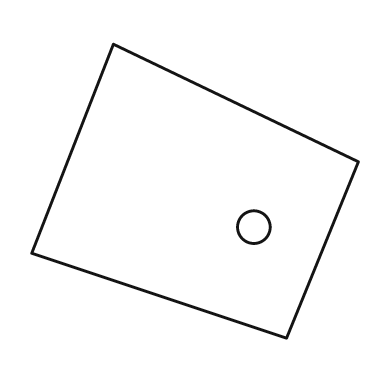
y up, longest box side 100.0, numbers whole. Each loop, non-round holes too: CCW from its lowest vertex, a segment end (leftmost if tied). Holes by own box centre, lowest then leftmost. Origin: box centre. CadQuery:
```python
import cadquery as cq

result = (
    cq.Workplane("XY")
    .moveTo(28.0, -45.0)
    .lineTo(50.0, 9.0)
    .lineTo(-25.0, 45.0)
    .lineTo(-50.0, -19.0)
    .close()
    .moveTo(18.0, -11.0)
    .circle(5.0)
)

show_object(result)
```